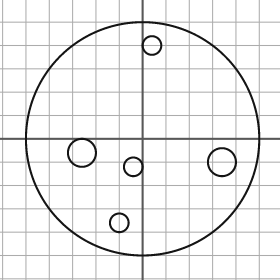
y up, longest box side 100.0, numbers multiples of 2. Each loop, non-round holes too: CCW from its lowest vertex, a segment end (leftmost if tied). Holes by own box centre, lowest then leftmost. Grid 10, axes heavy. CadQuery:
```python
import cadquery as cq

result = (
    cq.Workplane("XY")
    .moveTo(0.0, 0.0)
    .circle(50.0)
    .moveTo(-10.0, -36.0)
    .circle(4.0)
    .moveTo(-4.0, -12.0)
    .circle(4.0)
    .moveTo(34.0, -10.0)
    .circle(6.0)
    .moveTo(-26.0, -6.0)
    .circle(6.0)
    .moveTo(4.0, 40.0)
    .circle(4.0)
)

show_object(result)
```